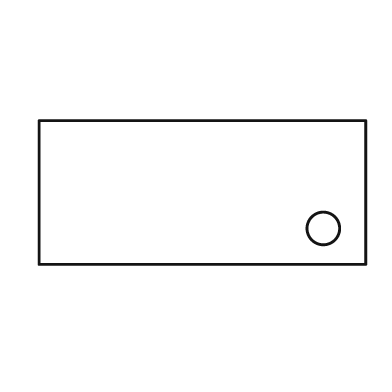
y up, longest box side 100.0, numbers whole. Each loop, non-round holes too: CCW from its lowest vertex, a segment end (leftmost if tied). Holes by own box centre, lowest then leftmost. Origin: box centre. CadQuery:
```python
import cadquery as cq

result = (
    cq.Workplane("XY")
    .moveTo(-50.0, -22.0)
    .lineTo(50.0, -22.0)
    .lineTo(50.0, 22.0)
    .lineTo(-50.0, 22.0)
    .close()
    .moveTo(37.0, -11.0)
    .circle(5.0)
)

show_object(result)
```